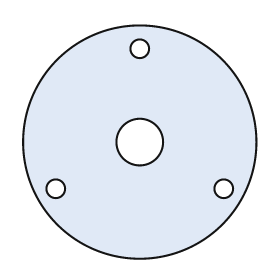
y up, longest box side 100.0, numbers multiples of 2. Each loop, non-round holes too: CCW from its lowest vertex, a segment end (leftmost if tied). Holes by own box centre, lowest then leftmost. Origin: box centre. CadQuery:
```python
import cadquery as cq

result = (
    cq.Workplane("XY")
    .moveTo(0.0, 0.0)
    .circle(50.0)
    .moveTo(-36.0, -20.0)
    .circle(4.0)
    .moveTo(36.0, -20.0)
    .circle(4.0)
    .moveTo(0.0, 0.0)
    .circle(10.0)
    .moveTo(0.0, 40.0)
    .circle(4.0)
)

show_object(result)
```